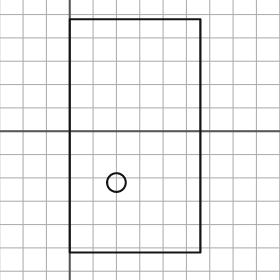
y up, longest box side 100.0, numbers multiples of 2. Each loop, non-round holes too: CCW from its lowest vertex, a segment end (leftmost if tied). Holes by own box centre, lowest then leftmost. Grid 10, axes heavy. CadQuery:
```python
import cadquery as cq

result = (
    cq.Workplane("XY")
    .moveTo(0.0, -52.0)
    .lineTo(56.0, -52.0)
    .lineTo(56.0, 48.0)
    .lineTo(0.0, 48.0)
    .close()
    .moveTo(20.0, -22.0)
    .circle(4.0)
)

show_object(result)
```